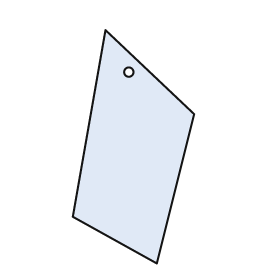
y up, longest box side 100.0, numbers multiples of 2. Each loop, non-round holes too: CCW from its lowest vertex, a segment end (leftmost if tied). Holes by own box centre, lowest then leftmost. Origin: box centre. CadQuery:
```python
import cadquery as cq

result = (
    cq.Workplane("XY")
    .moveTo(10.0, -50.0)
    .lineTo(26.0, 14.0)
    .lineTo(-12.0, 50.0)
    .lineTo(-26.0, -30.0)
    .close()
    .moveTo(-2.0, 32.0)
    .circle(2.0)
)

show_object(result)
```